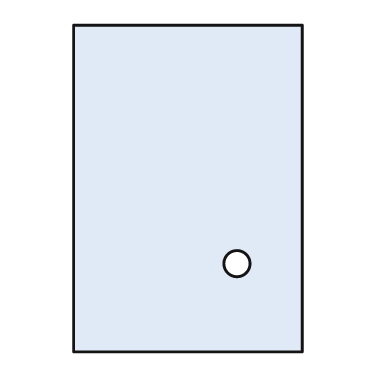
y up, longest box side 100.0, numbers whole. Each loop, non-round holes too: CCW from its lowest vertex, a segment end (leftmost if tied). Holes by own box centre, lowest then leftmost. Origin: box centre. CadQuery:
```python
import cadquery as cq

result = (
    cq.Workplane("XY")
    .moveTo(-35.0, -50.0)
    .lineTo(35.0, -50.0)
    .lineTo(35.0, 50.0)
    .lineTo(-35.0, 50.0)
    .close()
    .moveTo(15.0, -23.0)
    .circle(4.0)
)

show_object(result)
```